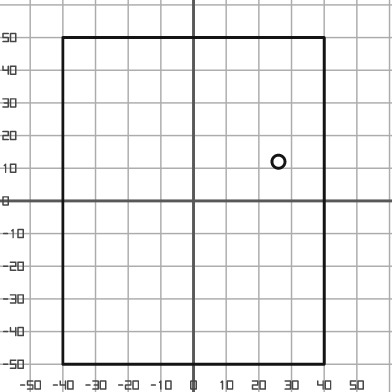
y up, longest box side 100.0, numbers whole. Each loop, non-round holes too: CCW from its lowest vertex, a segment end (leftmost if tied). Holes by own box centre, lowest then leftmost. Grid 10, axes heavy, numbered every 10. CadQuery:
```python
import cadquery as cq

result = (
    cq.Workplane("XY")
    .moveTo(-40.0, -50.0)
    .lineTo(40.0, -50.0)
    .lineTo(40.0, 50.0)
    .lineTo(-40.0, 50.0)
    .close()
    .moveTo(26.0, 12.0)
    .circle(2.0)
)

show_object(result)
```